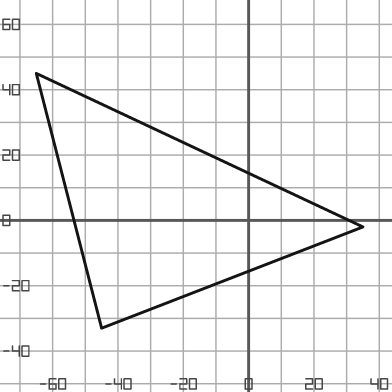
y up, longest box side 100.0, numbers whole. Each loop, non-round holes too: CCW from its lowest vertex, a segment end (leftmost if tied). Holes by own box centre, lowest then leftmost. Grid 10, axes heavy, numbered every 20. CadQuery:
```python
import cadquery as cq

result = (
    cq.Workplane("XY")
    .moveTo(-45.0, -33.0)
    .lineTo(35.0, -2.0)
    .lineTo(-65.0, 45.0)
    .close()
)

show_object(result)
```